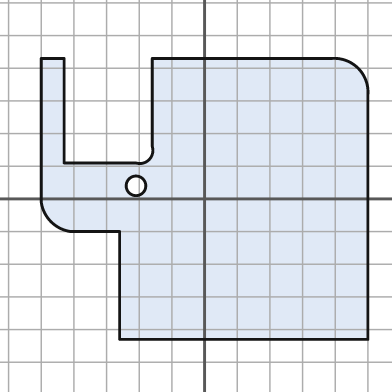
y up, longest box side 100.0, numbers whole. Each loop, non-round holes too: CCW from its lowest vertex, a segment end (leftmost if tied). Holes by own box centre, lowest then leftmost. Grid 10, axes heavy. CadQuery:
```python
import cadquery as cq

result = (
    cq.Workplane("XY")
    .moveTo(-26.0, -43.0)
    .lineTo(50.0, -43.0)
    .lineTo(50.0, 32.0)
    .threePointArc((47.0, 40.0), (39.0, 43.0))
    .lineTo(-16.0, 43.0)
    .lineTo(-16.0, 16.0)
    .threePointArc((-17.0, 12.0), (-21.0, 11.0))
    .lineTo(-43.0, 11.0)
    .lineTo(-43.0, 43.0)
    .lineTo(-50.0, 43.0)
    .lineTo(-50.0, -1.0)
    .threePointArc((-47.0, -7.0), (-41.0, -10.0))
    .lineTo(-26.0, -10.0)
    .close()
    .moveTo(-21.0, 4.0)
    .circle(3.0)
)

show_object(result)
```